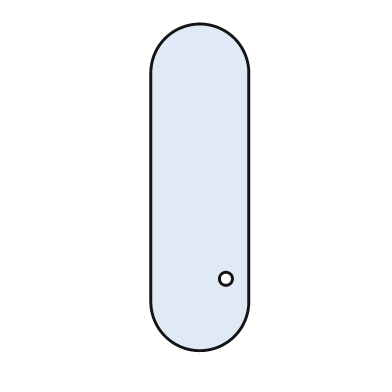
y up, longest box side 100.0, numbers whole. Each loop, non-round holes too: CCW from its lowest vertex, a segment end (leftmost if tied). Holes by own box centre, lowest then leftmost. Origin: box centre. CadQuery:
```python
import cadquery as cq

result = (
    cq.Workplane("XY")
    .moveTo(-15.0, -35.0)
    .threePointArc((0.0, -50.0), (15.0, -35.0))
    .lineTo(15.0, 35.0)
    .threePointArc((0.0, 50.0), (-15.0, 35.0))
    .close()
    .moveTo(8.0, -28.0)
    .circle(2.0)
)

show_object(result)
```